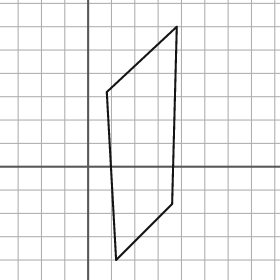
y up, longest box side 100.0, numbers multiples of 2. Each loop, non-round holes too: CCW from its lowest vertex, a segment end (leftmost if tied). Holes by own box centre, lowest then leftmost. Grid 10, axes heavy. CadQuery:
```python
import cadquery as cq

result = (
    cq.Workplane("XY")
    .moveTo(12.0, -40.0)
    .lineTo(36.0, -16.0)
    .lineTo(38.0, 60.0)
    .lineTo(8.0, 32.0)
    .close()
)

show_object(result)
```